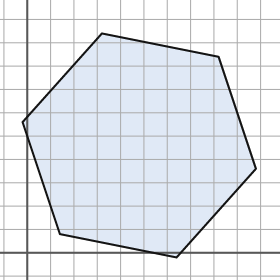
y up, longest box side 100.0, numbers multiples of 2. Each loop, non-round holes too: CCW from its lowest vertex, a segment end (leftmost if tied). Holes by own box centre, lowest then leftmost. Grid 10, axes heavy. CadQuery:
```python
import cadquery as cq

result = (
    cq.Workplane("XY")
    .moveTo(64.0, -2.0)
    .lineTo(98.0, 36.0)
    .lineTo(82.0, 84.0)
    .lineTo(32.0, 94.0)
    .lineTo(-2.0, 56.0)
    .lineTo(14.0, 8.0)
    .close()
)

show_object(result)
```